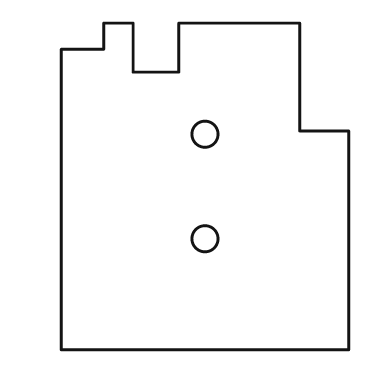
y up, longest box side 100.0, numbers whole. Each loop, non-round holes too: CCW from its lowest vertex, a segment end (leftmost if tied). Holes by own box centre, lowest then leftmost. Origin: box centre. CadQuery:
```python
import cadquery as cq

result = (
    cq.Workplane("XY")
    .moveTo(-44.0, -50.0)
    .lineTo(44.0, -50.0)
    .lineTo(44.0, 17.0)
    .lineTo(29.0, 17.0)
    .lineTo(29.0, 50.0)
    .lineTo(-8.0, 50.0)
    .lineTo(-8.0, 35.0)
    .lineTo(-22.0, 35.0)
    .lineTo(-22.0, 50.0)
    .lineTo(-31.0, 50.0)
    .lineTo(-31.0, 42.0)
    .lineTo(-44.0, 42.0)
    .close()
    .moveTo(0.0, -16.0)
    .circle(4.0)
    .moveTo(0.0, 16.0)
    .circle(4.0)
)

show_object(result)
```